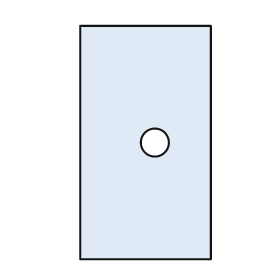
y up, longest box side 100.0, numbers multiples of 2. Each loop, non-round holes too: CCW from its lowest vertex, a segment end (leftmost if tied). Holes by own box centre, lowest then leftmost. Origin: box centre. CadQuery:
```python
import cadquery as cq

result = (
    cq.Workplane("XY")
    .moveTo(-28.0, -50.0)
    .lineTo(28.0, -50.0)
    .lineTo(28.0, 50.0)
    .lineTo(-28.0, 50.0)
    .close()
    .moveTo(4.0, 0.0)
    .circle(6.0)
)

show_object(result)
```